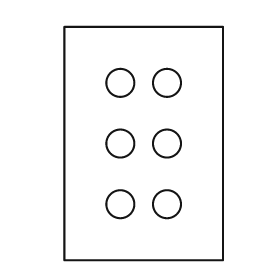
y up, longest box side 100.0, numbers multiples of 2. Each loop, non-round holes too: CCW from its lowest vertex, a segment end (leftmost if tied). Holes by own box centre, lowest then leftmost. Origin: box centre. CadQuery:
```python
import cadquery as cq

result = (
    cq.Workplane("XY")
    .moveTo(-34.0, -50.0)
    .lineTo(34.0, -50.0)
    .lineTo(34.0, 50.0)
    .lineTo(-34.0, 50.0)
    .close()
    .moveTo(-10.0, -26.0)
    .circle(6.0)
    .moveTo(10.0, -26.0)
    .circle(6.0)
    .moveTo(-10.0, 0.0)
    .circle(6.0)
    .moveTo(10.0, 0.0)
    .circle(6.0)
    .moveTo(-10.0, 26.0)
    .circle(6.0)
    .moveTo(10.0, 26.0)
    .circle(6.0)
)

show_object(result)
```